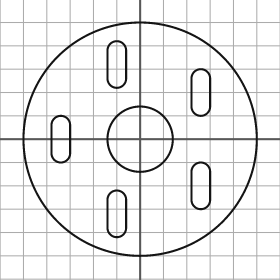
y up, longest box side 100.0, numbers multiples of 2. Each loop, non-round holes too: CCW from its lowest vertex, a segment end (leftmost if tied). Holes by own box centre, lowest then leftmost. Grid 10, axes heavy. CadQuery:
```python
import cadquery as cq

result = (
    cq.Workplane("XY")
    .moveTo(0.0, 0.0)
    .circle(50.0)
    .moveTo(-14.0, -38.0)
    .threePointArc((-10.0, -42.0), (-6.0, -38.0))
    .lineTo(-6.0, -26.0)
    .threePointArc((-10.0, -22.0), (-14.0, -26.0))
    .close()
    .moveTo(22.0, -26.0)
    .threePointArc((26.0, -30.0), (30.0, -26.0))
    .lineTo(30.0, -14.0)
    .threePointArc((26.0, -10.0), (22.0, -14.0))
    .close()
    .moveTo(-38.0, -6.0)
    .threePointArc((-34.0, -10.0), (-30.0, -6.0))
    .lineTo(-30.0, 6.0)
    .threePointArc((-34.0, 10.0), (-38.0, 6.0))
    .close()
    .moveTo(0.0, 0.0)
    .circle(14.0)
    .moveTo(22.0, 14.0)
    .threePointArc((26.0, 10.0), (30.0, 14.0))
    .lineTo(30.0, 26.0)
    .threePointArc((26.0, 30.0), (22.0, 26.0))
    .close()
    .moveTo(-14.0, 26.0)
    .threePointArc((-10.0, 22.0), (-6.0, 26.0))
    .lineTo(-6.0, 38.0)
    .threePointArc((-10.0, 42.0), (-14.0, 38.0))
    .close()
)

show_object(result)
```